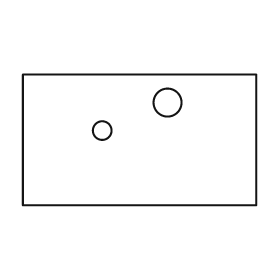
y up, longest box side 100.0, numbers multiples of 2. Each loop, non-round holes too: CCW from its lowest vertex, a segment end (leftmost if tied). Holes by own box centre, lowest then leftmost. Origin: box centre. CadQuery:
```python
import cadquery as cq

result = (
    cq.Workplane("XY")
    .moveTo(-50.0, -28.0)
    .lineTo(50.0, -28.0)
    .lineTo(50.0, 28.0)
    .lineTo(-50.0, 28.0)
    .close()
    .moveTo(-16.0, 4.0)
    .circle(4.0)
    .moveTo(12.0, 16.0)
    .circle(6.0)
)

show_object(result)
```